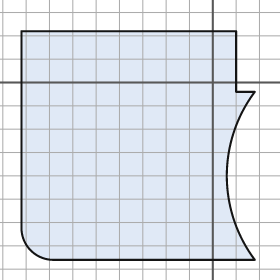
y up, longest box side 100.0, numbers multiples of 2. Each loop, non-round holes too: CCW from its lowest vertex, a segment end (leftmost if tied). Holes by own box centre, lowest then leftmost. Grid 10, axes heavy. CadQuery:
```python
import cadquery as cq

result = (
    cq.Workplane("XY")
    .moveTo(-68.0, -76.0)
    .lineTo(18.0, -76.0)
    .threePointArc((6.0, -40.0), (18.0, -4.0))
    .lineTo(10.0, -4.0)
    .lineTo(10.0, 22.0)
    .lineTo(-82.0, 22.0)
    .lineTo(-82.0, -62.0)
    .threePointArc((-78.0, -72.0), (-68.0, -76.0))
    .close()
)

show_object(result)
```